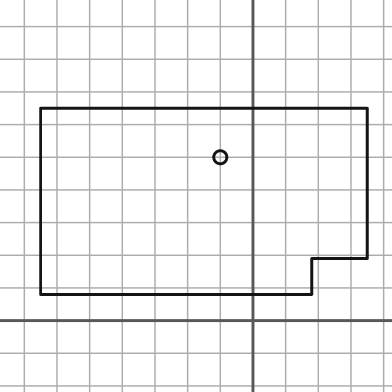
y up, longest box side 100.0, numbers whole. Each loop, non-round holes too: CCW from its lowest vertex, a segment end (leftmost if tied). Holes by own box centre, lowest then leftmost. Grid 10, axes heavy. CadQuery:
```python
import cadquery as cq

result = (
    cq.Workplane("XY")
    .moveTo(-65.0, 8.0)
    .lineTo(18.0, 8.0)
    .lineTo(18.0, 19.0)
    .lineTo(35.0, 19.0)
    .lineTo(35.0, 65.0)
    .lineTo(-65.0, 65.0)
    .close()
    .moveTo(-10.0, 50.0)
    .circle(2.0)
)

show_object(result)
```